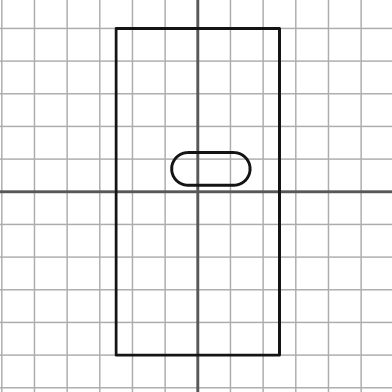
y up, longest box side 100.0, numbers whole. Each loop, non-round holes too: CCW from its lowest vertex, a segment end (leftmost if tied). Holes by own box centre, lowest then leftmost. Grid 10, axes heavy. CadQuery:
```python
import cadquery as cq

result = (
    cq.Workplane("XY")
    .moveTo(-25.0, -50.0)
    .lineTo(25.0, -50.0)
    .lineTo(25.0, 50.0)
    .lineTo(-25.0, 50.0)
    .close()
    .moveTo(-3.0, 2.0)
    .lineTo(11.0, 2.0)
    .threePointArc((16.0, 7.0), (11.0, 12.0))
    .lineTo(-3.0, 12.0)
    .threePointArc((-8.0, 7.0), (-3.0, 2.0))
    .close()
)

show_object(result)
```